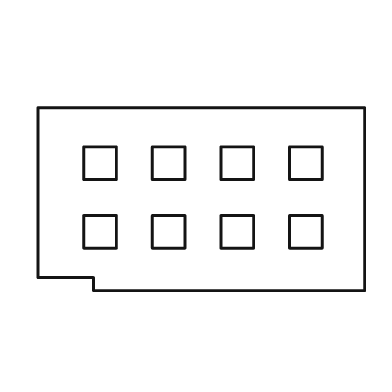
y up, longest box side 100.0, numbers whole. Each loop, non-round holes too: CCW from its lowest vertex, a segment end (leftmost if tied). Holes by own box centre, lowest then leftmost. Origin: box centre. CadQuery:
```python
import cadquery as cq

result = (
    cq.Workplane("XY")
    .moveTo(-33.0, -28.0)
    .lineTo(50.0, -28.0)
    .lineTo(50.0, 28.0)
    .lineTo(-50.0, 28.0)
    .lineTo(-50.0, -24.0)
    .lineTo(-33.0, -24.0)
    .close()
    .moveTo(-36.0, -15.0)
    .lineTo(-26.0, -15.0)
    .lineTo(-26.0, -5.0)
    .lineTo(-36.0, -5.0)
    .close()
    .moveTo(-15.0, -15.0)
    .lineTo(-5.0, -15.0)
    .lineTo(-5.0, -5.0)
    .lineTo(-15.0, -5.0)
    .close()
    .moveTo(6.0, -15.0)
    .lineTo(16.0, -15.0)
    .lineTo(16.0, -5.0)
    .lineTo(6.0, -5.0)
    .close()
    .moveTo(27.0, -15.0)
    .lineTo(37.0, -15.0)
    .lineTo(37.0, -5.0)
    .lineTo(27.0, -5.0)
    .close()
    .moveTo(-36.0, 6.0)
    .lineTo(-26.0, 6.0)
    .lineTo(-26.0, 16.0)
    .lineTo(-36.0, 16.0)
    .close()
    .moveTo(-15.0, 6.0)
    .lineTo(-5.0, 6.0)
    .lineTo(-5.0, 16.0)
    .lineTo(-15.0, 16.0)
    .close()
    .moveTo(6.0, 6.0)
    .lineTo(16.0, 6.0)
    .lineTo(16.0, 16.0)
    .lineTo(6.0, 16.0)
    .close()
    .moveTo(27.0, 6.0)
    .lineTo(37.0, 6.0)
    .lineTo(37.0, 16.0)
    .lineTo(27.0, 16.0)
    .close()
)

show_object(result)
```